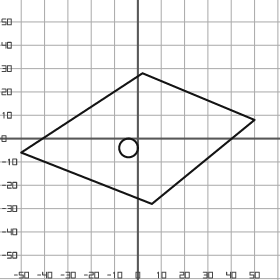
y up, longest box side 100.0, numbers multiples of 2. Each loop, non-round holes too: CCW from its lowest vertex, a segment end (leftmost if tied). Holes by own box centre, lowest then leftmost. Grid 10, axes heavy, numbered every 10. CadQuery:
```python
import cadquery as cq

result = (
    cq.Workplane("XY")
    .moveTo(6.0, -28.0)
    .lineTo(50.0, 8.0)
    .lineTo(2.0, 28.0)
    .lineTo(-50.0, -6.0)
    .close()
    .moveTo(-4.0, -4.0)
    .circle(4.0)
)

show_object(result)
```